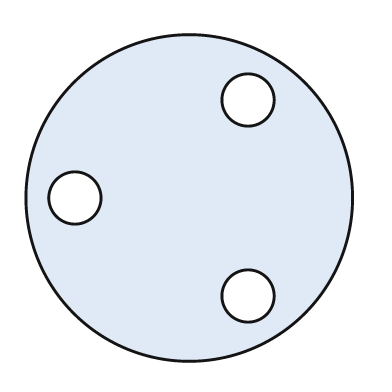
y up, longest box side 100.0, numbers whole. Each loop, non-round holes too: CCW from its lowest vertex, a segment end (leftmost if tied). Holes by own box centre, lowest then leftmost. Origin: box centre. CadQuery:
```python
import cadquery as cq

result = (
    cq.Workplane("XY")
    .moveTo(0.0, 0.0)
    .circle(50.0)
    .moveTo(18.0, -30.0)
    .circle(8.0)
    .moveTo(-35.0, 0.0)
    .circle(8.0)
    .moveTo(18.0, 30.0)
    .circle(8.0)
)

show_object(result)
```